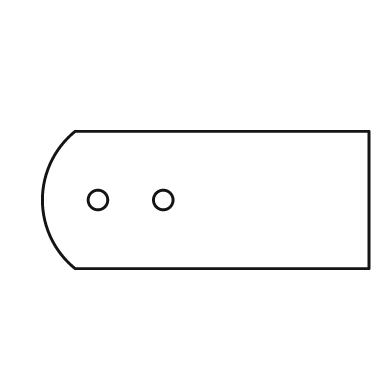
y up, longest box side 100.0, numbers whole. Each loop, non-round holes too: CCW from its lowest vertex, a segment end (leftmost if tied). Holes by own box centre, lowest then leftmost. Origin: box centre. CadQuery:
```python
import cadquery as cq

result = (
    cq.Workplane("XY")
    .moveTo(-40.0, -21.0)
    .lineTo(50.0, -21.0)
    .lineTo(50.0, 21.0)
    .lineTo(-40.0, 21.0)
    .threePointArc((-50.0, 0.0), (-40.0, -21.0))
    .close()
    .moveTo(-33.0, 0.0)
    .circle(3.0)
    .moveTo(-13.0, 0.0)
    .circle(3.0)
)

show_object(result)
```